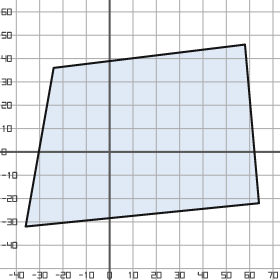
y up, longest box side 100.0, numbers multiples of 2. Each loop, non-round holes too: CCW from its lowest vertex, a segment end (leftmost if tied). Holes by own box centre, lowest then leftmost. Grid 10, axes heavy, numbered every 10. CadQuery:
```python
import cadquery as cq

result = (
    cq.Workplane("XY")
    .moveTo(-36.0, -32.0)
    .lineTo(64.0, -22.0)
    .lineTo(58.0, 46.0)
    .lineTo(-24.0, 36.0)
    .close()
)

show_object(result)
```